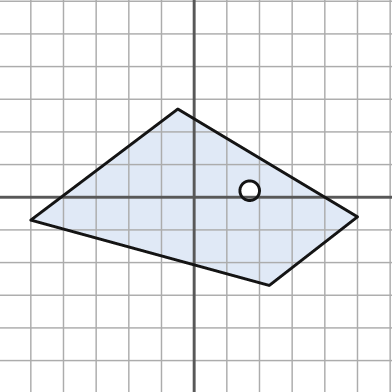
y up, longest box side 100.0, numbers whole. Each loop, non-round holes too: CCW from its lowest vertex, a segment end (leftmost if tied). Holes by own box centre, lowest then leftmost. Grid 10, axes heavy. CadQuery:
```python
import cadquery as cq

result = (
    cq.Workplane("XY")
    .moveTo(23.0, -27.0)
    .lineTo(50.0, -6.0)
    .lineTo(-5.0, 27.0)
    .lineTo(-50.0, -7.0)
    .close()
    .moveTo(17.0, 2.0)
    .circle(3.0)
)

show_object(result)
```